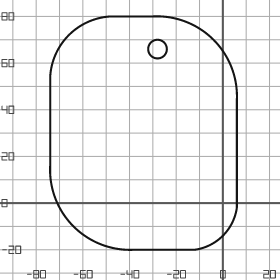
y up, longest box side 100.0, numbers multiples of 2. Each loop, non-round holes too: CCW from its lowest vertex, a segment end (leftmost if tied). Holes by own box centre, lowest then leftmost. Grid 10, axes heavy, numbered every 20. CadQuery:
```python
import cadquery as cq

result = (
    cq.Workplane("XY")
    .moveTo(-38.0, -20.0)
    .lineTo(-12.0, -20.0)
    .threePointArc((0.0, -14.0), (6.0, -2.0))
    .lineTo(6.0, 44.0)
    .threePointArc((-4.0, 70.0), (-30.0, 80.0))
    .lineTo(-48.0, 80.0)
    .threePointArc((-66.0, 72.0), (-74.0, 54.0))
    .lineTo(-74.0, 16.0)
    .threePointArc((-64.0, -10.0), (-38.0, -20.0))
    .close()
    .moveTo(-28.0, 66.0)
    .circle(4.0)
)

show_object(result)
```